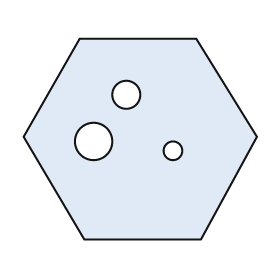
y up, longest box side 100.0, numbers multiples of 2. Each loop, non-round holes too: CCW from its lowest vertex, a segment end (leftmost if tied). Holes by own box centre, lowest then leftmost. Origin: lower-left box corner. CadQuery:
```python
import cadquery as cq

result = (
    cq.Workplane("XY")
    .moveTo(26.0, 0.0)
    .lineTo(76.0, 0.0)
    .lineTo(100.0, 44.0)
    .lineTo(74.0, 86.0)
    .lineTo(24.0, 86.0)
    .lineTo(0.0, 44.0)
    .close()
    .moveTo(64.0, 38.0)
    .circle(4.0)
    .moveTo(30.0, 42.0)
    .circle(8.0)
    .moveTo(44.0, 62.0)
    .circle(6.0)
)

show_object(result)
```